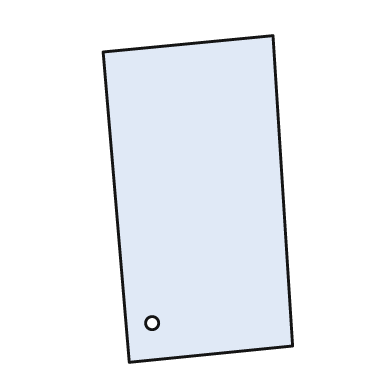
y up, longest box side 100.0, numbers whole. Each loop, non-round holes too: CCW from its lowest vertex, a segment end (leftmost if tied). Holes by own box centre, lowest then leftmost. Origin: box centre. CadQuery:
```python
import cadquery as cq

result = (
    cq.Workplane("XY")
    .moveTo(-21.0, -50.0)
    .lineTo(29.0, -45.0)
    .lineTo(23.0, 50.0)
    .lineTo(-29.0, 45.0)
    .close()
    .moveTo(-14.0, -38.0)
    .circle(2.0)
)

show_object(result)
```